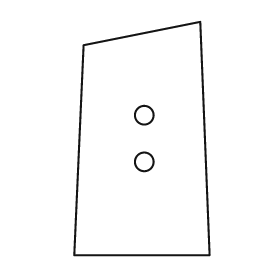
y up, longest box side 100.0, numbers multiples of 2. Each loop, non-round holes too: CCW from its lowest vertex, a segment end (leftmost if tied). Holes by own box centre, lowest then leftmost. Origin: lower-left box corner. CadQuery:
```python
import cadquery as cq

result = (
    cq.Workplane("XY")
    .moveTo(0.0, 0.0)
    .lineTo(58.0, 0.0)
    .lineTo(54.0, 100.0)
    .lineTo(4.0, 90.0)
    .close()
    .moveTo(30.0, 40.0)
    .circle(4.0)
    .moveTo(30.0, 60.0)
    .circle(4.0)
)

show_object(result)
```